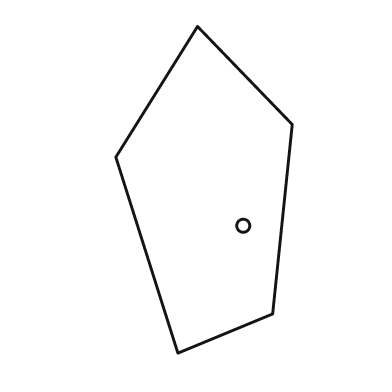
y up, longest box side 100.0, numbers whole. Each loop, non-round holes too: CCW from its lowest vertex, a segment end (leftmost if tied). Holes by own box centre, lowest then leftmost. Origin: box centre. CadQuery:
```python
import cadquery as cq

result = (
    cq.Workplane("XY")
    .moveTo(-8.0, -50.0)
    .lineTo(21.0, -38.0)
    .lineTo(27.0, 20.0)
    .lineTo(-2.0, 50.0)
    .lineTo(-27.0, 10.0)
    .close()
    .moveTo(12.0, -11.0)
    .circle(2.0)
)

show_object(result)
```